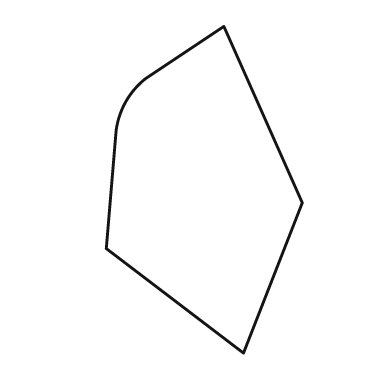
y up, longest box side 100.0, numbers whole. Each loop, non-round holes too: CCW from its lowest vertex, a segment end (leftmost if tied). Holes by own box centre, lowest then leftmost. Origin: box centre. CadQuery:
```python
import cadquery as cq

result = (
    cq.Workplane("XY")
    .moveTo(12.0, -50.0)
    .lineTo(30.0, -4.0)
    .lineTo(6.0, 50.0)
    .lineTo(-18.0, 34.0)
    .threePointArc((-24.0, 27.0), (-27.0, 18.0))
    .lineTo(-30.0, -18.0)
    .close()
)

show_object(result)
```